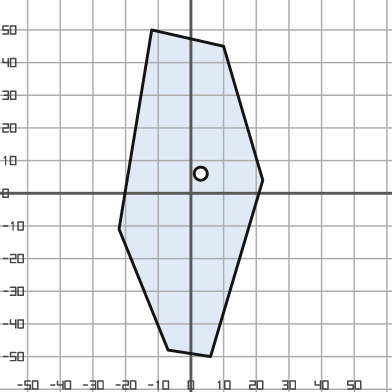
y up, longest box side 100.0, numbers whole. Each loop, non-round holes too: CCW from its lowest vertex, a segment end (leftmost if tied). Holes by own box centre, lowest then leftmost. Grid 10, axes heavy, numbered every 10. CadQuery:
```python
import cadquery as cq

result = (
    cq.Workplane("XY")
    .moveTo(6.0, -50.0)
    .lineTo(22.0, 4.0)
    .lineTo(10.0, 45.0)
    .lineTo(-12.0, 50.0)
    .lineTo(-22.0, -11.0)
    .lineTo(-7.0, -48.0)
    .close()
    .moveTo(3.0, 6.0)
    .circle(2.0)
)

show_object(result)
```